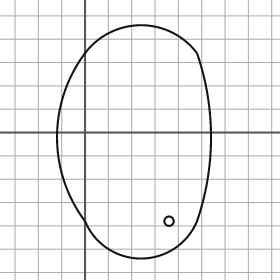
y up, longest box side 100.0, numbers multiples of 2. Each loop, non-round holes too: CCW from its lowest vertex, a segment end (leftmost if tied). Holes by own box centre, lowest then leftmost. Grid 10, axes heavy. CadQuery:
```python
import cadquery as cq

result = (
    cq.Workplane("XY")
    .moveTo(0.0, -38.0)
    .threePointArc((24.0, -54.0), (48.0, -38.0))
    .threePointArc((54.0, -2.0), (48.0, 34.0))
    .threePointArc((24.0, 46.0), (0.0, 34.0))
    .threePointArc((-12.0, -2.0), (0.0, -38.0))
    .close()
    .moveTo(36.0, -38.0)
    .circle(2.0)
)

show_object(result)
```